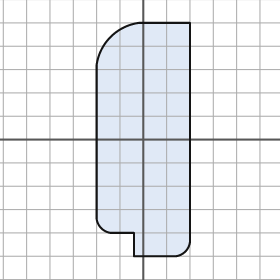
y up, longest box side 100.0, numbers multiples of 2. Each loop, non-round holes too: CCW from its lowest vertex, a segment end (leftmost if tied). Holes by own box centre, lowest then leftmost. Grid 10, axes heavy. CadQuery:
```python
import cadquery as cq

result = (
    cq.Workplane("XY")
    .moveTo(-4.0, -50.0)
    .lineTo(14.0, -50.0)
    .threePointArc((18.0, -48.0), (20.0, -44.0))
    .lineTo(20.0, 50.0)
    .lineTo(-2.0, 50.0)
    .threePointArc((-14.0, 44.0), (-20.0, 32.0))
    .lineTo(-20.0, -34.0)
    .threePointArc((-18.0, -38.0), (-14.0, -40.0))
    .lineTo(-4.0, -40.0)
    .close()
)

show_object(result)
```